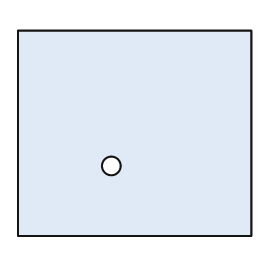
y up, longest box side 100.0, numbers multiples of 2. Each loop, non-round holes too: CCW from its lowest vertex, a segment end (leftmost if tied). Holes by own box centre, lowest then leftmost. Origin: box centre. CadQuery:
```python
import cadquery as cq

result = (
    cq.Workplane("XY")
    .moveTo(-50.0, -44.0)
    .lineTo(50.0, -44.0)
    .lineTo(50.0, 44.0)
    .lineTo(-50.0, 44.0)
    .close()
    .moveTo(-10.0, -14.0)
    .circle(4.0)
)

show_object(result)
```